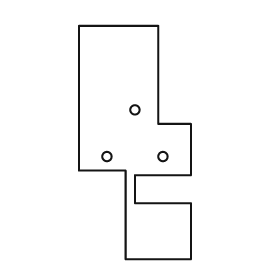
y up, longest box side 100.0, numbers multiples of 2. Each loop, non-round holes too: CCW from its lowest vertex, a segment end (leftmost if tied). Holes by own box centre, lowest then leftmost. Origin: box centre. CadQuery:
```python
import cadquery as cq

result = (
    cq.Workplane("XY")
    .moveTo(-4.0, -50.0)
    .lineTo(24.0, -50.0)
    .lineTo(24.0, -26.0)
    .lineTo(0.0, -26.0)
    .lineTo(0.0, -14.0)
    .lineTo(24.0, -14.0)
    .lineTo(24.0, 8.0)
    .lineTo(10.0, 8.0)
    .lineTo(10.0, 50.0)
    .lineTo(-24.0, 50.0)
    .lineTo(-24.0, -12.0)
    .lineTo(-4.0, -12.0)
    .close()
    .moveTo(-12.0, -6.0)
    .circle(2.0)
    .moveTo(12.0, -6.0)
    .circle(2.0)
    .moveTo(0.0, 14.0)
    .circle(2.0)
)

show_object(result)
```